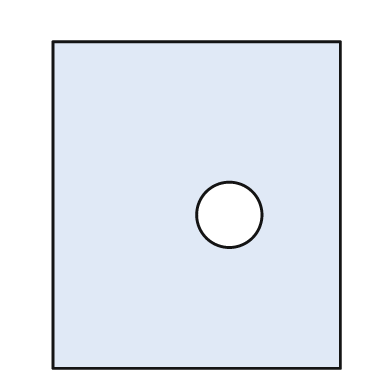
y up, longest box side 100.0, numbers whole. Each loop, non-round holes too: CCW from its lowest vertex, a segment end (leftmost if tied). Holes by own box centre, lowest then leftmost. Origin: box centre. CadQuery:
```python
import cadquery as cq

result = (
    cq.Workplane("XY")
    .moveTo(-44.0, -50.0)
    .lineTo(44.0, -50.0)
    .lineTo(44.0, 50.0)
    .lineTo(-44.0, 50.0)
    .close()
    .moveTo(10.0, -3.0)
    .circle(10.0)
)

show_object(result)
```